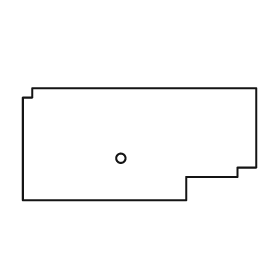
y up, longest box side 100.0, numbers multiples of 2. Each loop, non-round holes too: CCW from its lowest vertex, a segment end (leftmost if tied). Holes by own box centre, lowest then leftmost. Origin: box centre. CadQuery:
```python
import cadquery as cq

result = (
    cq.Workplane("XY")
    .moveTo(-50.0, -24.0)
    .lineTo(20.0, -24.0)
    .lineTo(20.0, -14.0)
    .lineTo(42.0, -14.0)
    .lineTo(42.0, -10.0)
    .lineTo(50.0, -10.0)
    .lineTo(50.0, 24.0)
    .lineTo(-46.0, 24.0)
    .lineTo(-46.0, 20.0)
    .lineTo(-50.0, 20.0)
    .close()
    .moveTo(-8.0, -6.0)
    .circle(2.0)
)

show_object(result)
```